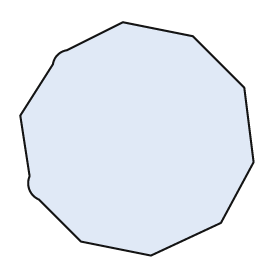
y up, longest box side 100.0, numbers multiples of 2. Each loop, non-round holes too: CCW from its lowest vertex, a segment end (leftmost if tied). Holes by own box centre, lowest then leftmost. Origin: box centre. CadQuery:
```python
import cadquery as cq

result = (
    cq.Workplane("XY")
    .moveTo(6.0, -50.0)
    .lineTo(36.0, -36.0)
    .lineTo(50.0, -10.0)
    .lineTo(46.0, 22.0)
    .lineTo(24.0, 44.0)
    .lineTo(-6.0, 50.0)
    .lineTo(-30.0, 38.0)
    .threePointArc((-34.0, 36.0), (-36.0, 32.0))
    .lineTo(-50.0, 10.0)
    .lineTo(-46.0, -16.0)
    .threePointArc((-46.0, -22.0), (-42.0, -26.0))
    .lineTo(-24.0, -44.0)
    .close()
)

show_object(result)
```